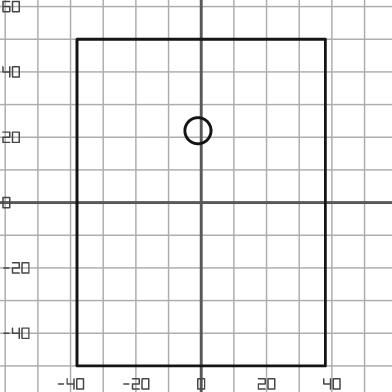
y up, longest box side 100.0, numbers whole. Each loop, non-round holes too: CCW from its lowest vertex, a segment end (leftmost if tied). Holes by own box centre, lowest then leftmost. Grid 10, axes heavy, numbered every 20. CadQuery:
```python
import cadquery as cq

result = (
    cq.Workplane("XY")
    .moveTo(-38.0, -50.0)
    .lineTo(38.0, -50.0)
    .lineTo(38.0, 50.0)
    .lineTo(-38.0, 50.0)
    .close()
    .moveTo(-1.0, 22.0)
    .circle(4.0)
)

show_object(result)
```